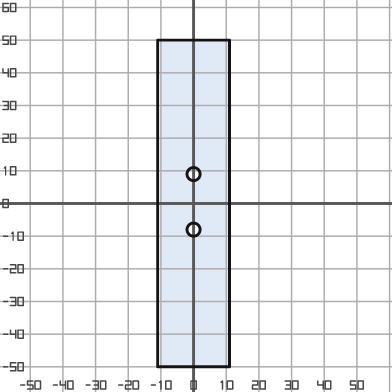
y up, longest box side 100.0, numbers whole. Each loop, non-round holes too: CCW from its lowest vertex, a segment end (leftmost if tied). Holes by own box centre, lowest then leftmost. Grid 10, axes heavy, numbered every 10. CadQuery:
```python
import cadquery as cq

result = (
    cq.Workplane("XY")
    .moveTo(-11.0, -50.0)
    .lineTo(11.0, -50.0)
    .lineTo(11.0, 50.0)
    .lineTo(-11.0, 50.0)
    .close()
    .moveTo(0.0, -8.0)
    .circle(2.0)
    .moveTo(0.0, 9.0)
    .circle(2.0)
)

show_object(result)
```